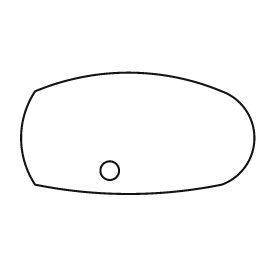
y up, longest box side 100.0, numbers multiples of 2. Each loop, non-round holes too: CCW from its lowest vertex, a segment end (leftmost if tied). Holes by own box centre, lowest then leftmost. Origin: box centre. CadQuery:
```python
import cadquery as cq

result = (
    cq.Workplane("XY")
    .moveTo(-44.0, -22.0)
    .threePointArc((-4.0, -26.0), (36.0, -22.0))
    .threePointArc((50.0, -2.0), (36.0, 18.0))
    .threePointArc((-4.0, 26.0), (-44.0, 18.0))
    .threePointArc((-50.0, -2.0), (-44.0, -22.0))
    .close()
    .moveTo(-12.0, -16.0)
    .circle(4.0)
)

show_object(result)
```